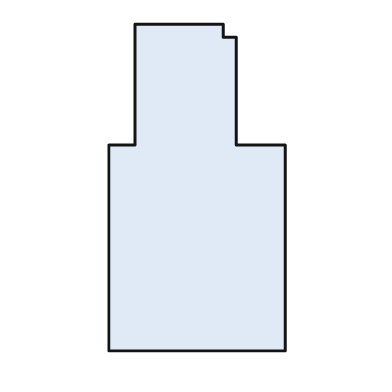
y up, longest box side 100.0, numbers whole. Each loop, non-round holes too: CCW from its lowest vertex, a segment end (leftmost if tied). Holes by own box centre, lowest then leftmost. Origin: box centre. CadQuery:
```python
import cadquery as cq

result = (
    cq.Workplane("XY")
    .moveTo(-27.0, -50.0)
    .lineTo(27.0, -50.0)
    .lineTo(27.0, 13.0)
    .lineTo(12.0, 13.0)
    .lineTo(12.0, 46.0)
    .lineTo(8.0, 46.0)
    .lineTo(8.0, 50.0)
    .lineTo(-19.0, 50.0)
    .lineTo(-19.0, 13.0)
    .lineTo(-27.0, 13.0)
    .close()
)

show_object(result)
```